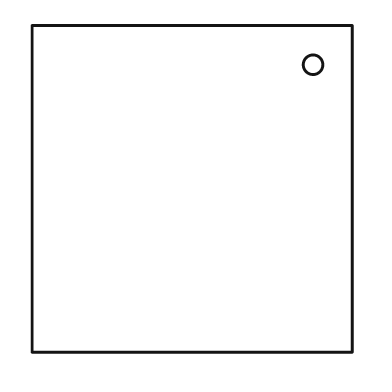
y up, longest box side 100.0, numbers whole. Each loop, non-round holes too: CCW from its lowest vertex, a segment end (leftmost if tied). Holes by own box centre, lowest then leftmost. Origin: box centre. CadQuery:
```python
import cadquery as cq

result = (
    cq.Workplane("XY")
    .moveTo(-49.0, -50.0)
    .lineTo(49.0, -50.0)
    .lineTo(49.0, 50.0)
    .lineTo(-49.0, 50.0)
    .close()
    .moveTo(37.0, 38.0)
    .circle(3.0)
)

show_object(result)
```